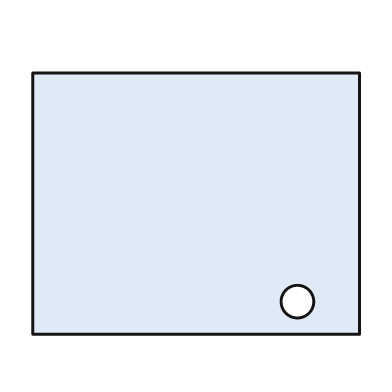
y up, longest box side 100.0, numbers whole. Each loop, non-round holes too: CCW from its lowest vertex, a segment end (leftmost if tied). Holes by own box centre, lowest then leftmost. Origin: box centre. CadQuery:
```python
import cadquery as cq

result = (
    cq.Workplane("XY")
    .moveTo(-50.0, -40.0)
    .lineTo(50.0, -40.0)
    .lineTo(50.0, 40.0)
    .lineTo(-50.0, 40.0)
    .close()
    .moveTo(31.0, -30.0)
    .circle(5.0)
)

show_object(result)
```